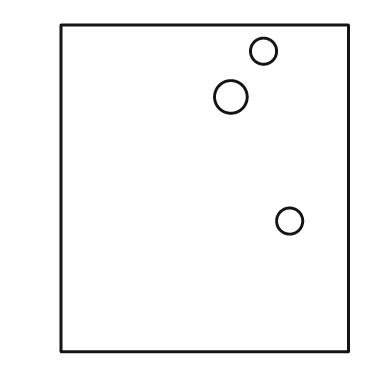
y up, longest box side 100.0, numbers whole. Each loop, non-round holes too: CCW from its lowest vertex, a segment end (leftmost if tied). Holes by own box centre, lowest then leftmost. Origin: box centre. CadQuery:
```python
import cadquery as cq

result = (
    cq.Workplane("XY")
    .moveTo(-44.0, -50.0)
    .lineTo(44.0, -50.0)
    .lineTo(44.0, 50.0)
    .lineTo(-44.0, 50.0)
    .close()
    .moveTo(26.0, -10.0)
    .circle(4.0)
    .moveTo(8.0, 28.0)
    .circle(5.0)
    .moveTo(18.0, 42.0)
    .circle(4.0)
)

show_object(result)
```